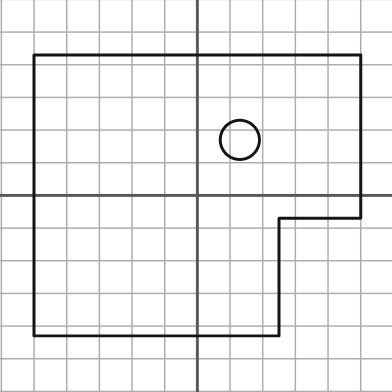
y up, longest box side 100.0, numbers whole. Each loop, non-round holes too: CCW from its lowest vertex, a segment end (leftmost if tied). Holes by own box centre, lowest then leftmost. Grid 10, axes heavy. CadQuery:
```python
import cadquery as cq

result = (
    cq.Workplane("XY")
    .moveTo(-50.0, -43.0)
    .lineTo(25.0, -43.0)
    .lineTo(25.0, -7.0)
    .lineTo(50.0, -7.0)
    .lineTo(50.0, 43.0)
    .lineTo(-50.0, 43.0)
    .close()
    .moveTo(13.0, 17.0)
    .circle(6.0)
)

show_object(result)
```